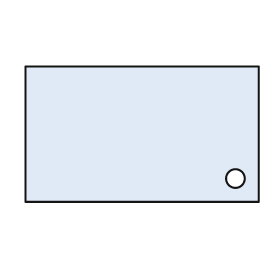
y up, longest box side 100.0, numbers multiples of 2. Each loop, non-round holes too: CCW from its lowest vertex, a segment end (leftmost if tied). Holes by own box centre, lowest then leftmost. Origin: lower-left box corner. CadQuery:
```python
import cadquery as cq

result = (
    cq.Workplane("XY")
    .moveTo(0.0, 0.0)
    .lineTo(100.0, 0.0)
    .lineTo(100.0, 58.0)
    .lineTo(0.0, 58.0)
    .close()
    .moveTo(90.0, 10.0)
    .circle(4.0)
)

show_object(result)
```